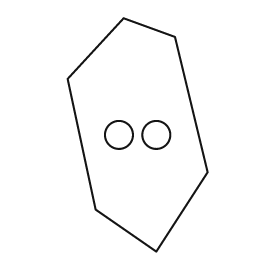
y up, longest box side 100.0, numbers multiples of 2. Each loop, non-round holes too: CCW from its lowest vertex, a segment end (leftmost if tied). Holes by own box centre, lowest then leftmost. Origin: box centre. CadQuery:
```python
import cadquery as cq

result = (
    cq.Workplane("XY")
    .moveTo(8.0, -50.0)
    .lineTo(30.0, -16.0)
    .lineTo(16.0, 42.0)
    .lineTo(-6.0, 50.0)
    .lineTo(-30.0, 24.0)
    .lineTo(-18.0, -32.0)
    .close()
    .moveTo(-8.0, 0.0)
    .circle(6.0)
    .moveTo(8.0, 0.0)
    .circle(6.0)
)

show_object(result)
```